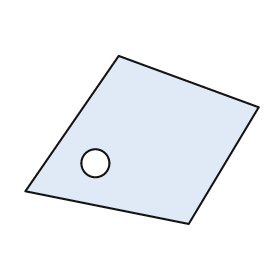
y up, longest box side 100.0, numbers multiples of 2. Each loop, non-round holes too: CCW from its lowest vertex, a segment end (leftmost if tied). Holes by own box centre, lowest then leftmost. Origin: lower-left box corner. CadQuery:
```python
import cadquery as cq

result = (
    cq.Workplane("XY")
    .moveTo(70.0, 0.0)
    .lineTo(100.0, 50.0)
    .lineTo(40.0, 72.0)
    .lineTo(0.0, 14.0)
    .close()
    .moveTo(30.0, 26.0)
    .circle(6.0)
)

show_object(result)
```